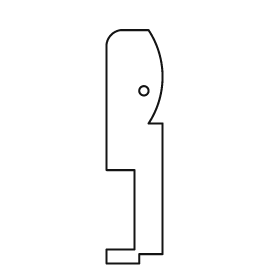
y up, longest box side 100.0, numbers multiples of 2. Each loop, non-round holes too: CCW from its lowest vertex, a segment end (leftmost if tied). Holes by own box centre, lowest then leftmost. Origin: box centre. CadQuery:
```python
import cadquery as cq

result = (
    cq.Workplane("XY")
    .moveTo(-12.0, -50.0)
    .lineTo(2.0, -50.0)
    .lineTo(2.0, -46.0)
    .lineTo(12.0, -46.0)
    .lineTo(12.0, 10.0)
    .lineTo(6.0, 10.0)
    .threePointArc((12.0, 30.0), (6.0, 50.0))
    .lineTo(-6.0, 50.0)
    .threePointArc((-10.0, 48.0), (-12.0, 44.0))
    .lineTo(-12.0, -10.0)
    .lineTo(0.0, -10.0)
    .lineTo(0.0, -44.0)
    .lineTo(-12.0, -44.0)
    .close()
    .moveTo(4.0, 24.0)
    .circle(2.0)
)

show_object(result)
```